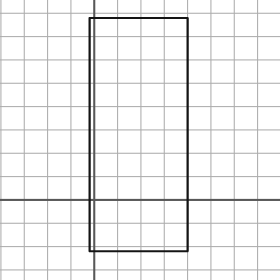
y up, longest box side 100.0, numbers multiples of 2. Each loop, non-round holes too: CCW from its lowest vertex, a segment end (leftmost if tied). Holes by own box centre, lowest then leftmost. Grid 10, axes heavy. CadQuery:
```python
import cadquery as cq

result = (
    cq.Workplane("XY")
    .moveTo(-2.0, -22.0)
    .lineTo(40.0, -22.0)
    .lineTo(40.0, 78.0)
    .lineTo(-2.0, 78.0)
    .close()
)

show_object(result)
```